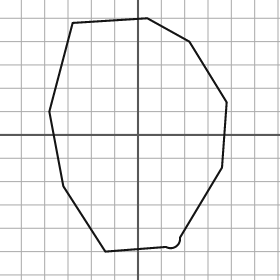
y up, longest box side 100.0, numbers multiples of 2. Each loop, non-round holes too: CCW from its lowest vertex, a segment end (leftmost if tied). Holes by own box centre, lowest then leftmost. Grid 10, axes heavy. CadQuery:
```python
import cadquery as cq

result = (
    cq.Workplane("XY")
    .moveTo(-14.0, -50.0)
    .lineTo(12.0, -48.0)
    .threePointArc((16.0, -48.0), (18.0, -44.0))
    .lineTo(36.0, -14.0)
    .lineTo(38.0, 14.0)
    .lineTo(22.0, 40.0)
    .lineTo(4.0, 50.0)
    .lineTo(-28.0, 48.0)
    .lineTo(-38.0, 10.0)
    .lineTo(-32.0, -22.0)
    .close()
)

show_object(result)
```